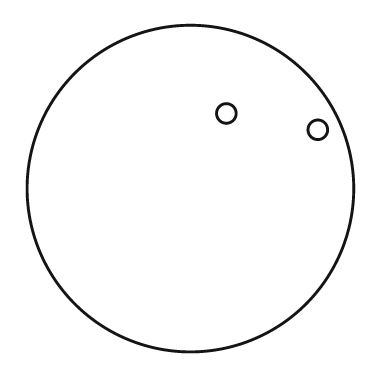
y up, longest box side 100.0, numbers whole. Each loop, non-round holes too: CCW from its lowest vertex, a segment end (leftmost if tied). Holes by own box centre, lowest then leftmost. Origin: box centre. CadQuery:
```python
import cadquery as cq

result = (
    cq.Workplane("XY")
    .moveTo(0.0, 0.0)
    .circle(50.0)
    .moveTo(39.0, 18.0)
    .circle(3.0)
    .moveTo(11.0, 23.0)
    .circle(3.0)
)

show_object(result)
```